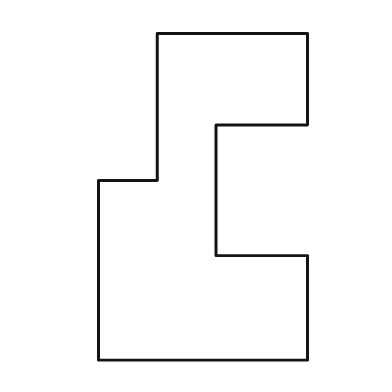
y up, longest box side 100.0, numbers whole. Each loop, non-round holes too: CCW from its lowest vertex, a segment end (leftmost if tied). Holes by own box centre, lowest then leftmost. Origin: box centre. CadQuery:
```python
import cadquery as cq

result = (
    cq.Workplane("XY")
    .moveTo(-32.0, -50.0)
    .lineTo(32.0, -50.0)
    .lineTo(32.0, -18.0)
    .lineTo(4.0, -18.0)
    .lineTo(4.0, 22.0)
    .lineTo(32.0, 22.0)
    .lineTo(32.0, 50.0)
    .lineTo(-14.0, 50.0)
    .lineTo(-14.0, 5.0)
    .lineTo(-32.0, 5.0)
    .close()
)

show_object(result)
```